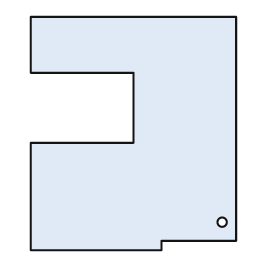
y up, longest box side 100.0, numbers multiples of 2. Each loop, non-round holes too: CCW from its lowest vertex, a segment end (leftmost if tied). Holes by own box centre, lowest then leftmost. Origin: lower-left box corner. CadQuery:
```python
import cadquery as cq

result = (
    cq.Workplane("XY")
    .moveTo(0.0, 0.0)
    .lineTo(56.0, 0.0)
    .lineTo(56.0, 4.0)
    .lineTo(88.0, 4.0)
    .lineTo(88.0, 100.0)
    .lineTo(0.0, 100.0)
    .lineTo(0.0, 76.0)
    .lineTo(44.0, 76.0)
    .lineTo(44.0, 46.0)
    .lineTo(0.0, 46.0)
    .close()
    .moveTo(82.0, 12.0)
    .circle(2.0)
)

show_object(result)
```